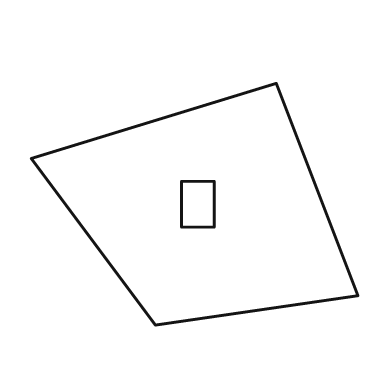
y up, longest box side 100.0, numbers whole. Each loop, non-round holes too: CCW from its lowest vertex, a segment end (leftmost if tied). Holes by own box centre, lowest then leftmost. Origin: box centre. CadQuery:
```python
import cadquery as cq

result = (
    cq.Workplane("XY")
    .moveTo(-12.0, -37.0)
    .lineTo(50.0, -28.0)
    .lineTo(25.0, 37.0)
    .lineTo(-50.0, 14.0)
    .close()
    .moveTo(-4.0, -7.0)
    .lineTo(6.0, -7.0)
    .lineTo(6.0, 7.0)
    .lineTo(-4.0, 7.0)
    .close()
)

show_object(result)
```